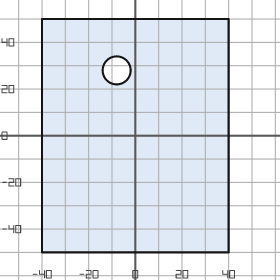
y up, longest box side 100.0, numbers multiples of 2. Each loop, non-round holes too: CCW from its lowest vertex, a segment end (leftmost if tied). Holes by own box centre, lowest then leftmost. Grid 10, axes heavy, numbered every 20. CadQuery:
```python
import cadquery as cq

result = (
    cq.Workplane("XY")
    .moveTo(-40.0, -50.0)
    .lineTo(40.0, -50.0)
    .lineTo(40.0, 50.0)
    .lineTo(-40.0, 50.0)
    .close()
    .moveTo(-8.0, 28.0)
    .circle(6.0)
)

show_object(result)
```